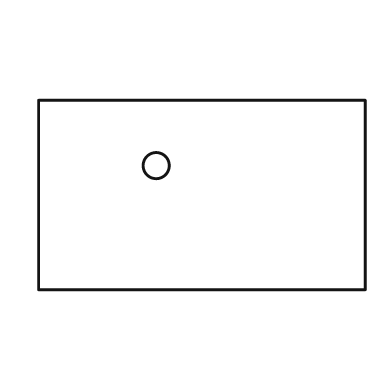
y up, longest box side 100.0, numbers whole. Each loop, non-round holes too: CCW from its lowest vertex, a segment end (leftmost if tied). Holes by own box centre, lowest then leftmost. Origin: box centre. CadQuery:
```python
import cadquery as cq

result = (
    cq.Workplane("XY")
    .moveTo(-50.0, -29.0)
    .lineTo(50.0, -29.0)
    .lineTo(50.0, 29.0)
    .lineTo(-50.0, 29.0)
    .close()
    .moveTo(-14.0, 9.0)
    .circle(4.0)
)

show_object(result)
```